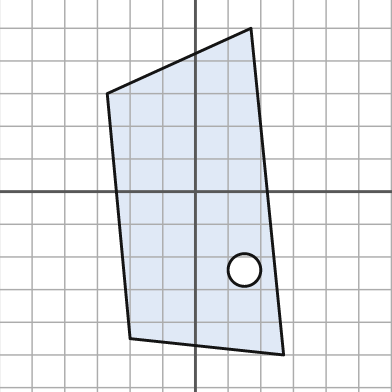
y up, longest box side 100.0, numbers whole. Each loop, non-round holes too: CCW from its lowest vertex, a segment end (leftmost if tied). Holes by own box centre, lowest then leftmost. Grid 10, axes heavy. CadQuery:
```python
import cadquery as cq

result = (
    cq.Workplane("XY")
    .moveTo(27.0, -50.0)
    .lineTo(17.0, 50.0)
    .lineTo(-27.0, 30.0)
    .lineTo(-20.0, -45.0)
    .close()
    .moveTo(15.0, -24.0)
    .circle(5.0)
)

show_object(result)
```